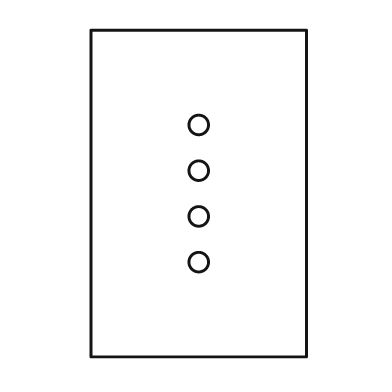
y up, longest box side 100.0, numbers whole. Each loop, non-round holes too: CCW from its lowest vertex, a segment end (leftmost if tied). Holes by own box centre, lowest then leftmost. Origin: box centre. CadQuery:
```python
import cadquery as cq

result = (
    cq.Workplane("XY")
    .moveTo(-33.0, -50.0)
    .lineTo(33.0, -50.0)
    .lineTo(33.0, 50.0)
    .lineTo(-33.0, 50.0)
    .close()
    .moveTo(0.0, -21.0)
    .circle(3.0)
    .moveTo(0.0, -7.0)
    .circle(3.0)
    .moveTo(0.0, 7.0)
    .circle(3.0)
    .moveTo(0.0, 21.0)
    .circle(3.0)
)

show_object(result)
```